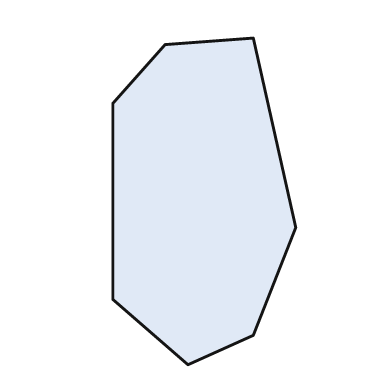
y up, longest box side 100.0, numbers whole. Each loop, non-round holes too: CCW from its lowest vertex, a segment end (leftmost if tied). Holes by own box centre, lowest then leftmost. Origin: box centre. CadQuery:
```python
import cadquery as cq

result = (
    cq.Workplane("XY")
    .moveTo(-5.0, -50.0)
    .lineTo(15.0, -41.0)
    .lineTo(28.0, -8.0)
    .lineTo(15.0, 50.0)
    .lineTo(-12.0, 48.0)
    .lineTo(-28.0, 30.0)
    .lineTo(-28.0, -30.0)
    .close()
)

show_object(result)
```